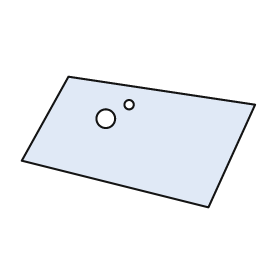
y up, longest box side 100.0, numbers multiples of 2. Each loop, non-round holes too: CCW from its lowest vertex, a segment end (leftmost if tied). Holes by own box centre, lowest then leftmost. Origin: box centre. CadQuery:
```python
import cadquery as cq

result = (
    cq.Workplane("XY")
    .moveTo(30.0, -28.0)
    .lineTo(50.0, 16.0)
    .lineTo(-30.0, 28.0)
    .lineTo(-50.0, -8.0)
    .close()
    .moveTo(-14.0, 10.0)
    .circle(4.0)
    .moveTo(-4.0, 16.0)
    .circle(2.0)
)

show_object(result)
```